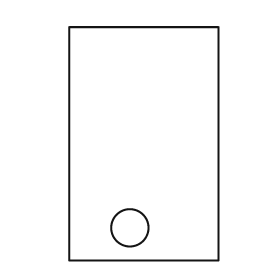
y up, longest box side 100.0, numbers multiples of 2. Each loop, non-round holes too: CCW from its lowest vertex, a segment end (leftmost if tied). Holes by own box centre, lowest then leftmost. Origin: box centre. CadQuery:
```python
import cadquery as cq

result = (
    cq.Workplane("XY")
    .moveTo(-32.0, -50.0)
    .lineTo(32.0, -50.0)
    .lineTo(32.0, 50.0)
    .lineTo(-32.0, 50.0)
    .close()
    .moveTo(-6.0, -36.0)
    .circle(8.0)
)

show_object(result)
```